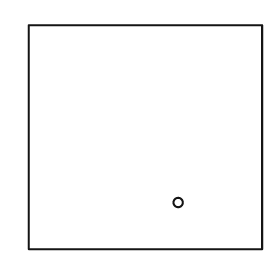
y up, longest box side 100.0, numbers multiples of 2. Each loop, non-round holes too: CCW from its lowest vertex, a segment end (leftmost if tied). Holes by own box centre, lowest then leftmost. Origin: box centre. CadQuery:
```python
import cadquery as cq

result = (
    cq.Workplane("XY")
    .moveTo(-50.0, -48.0)
    .lineTo(50.0, -48.0)
    .lineTo(50.0, 48.0)
    .lineTo(-50.0, 48.0)
    .close()
    .moveTo(14.0, -28.0)
    .circle(2.0)
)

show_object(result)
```